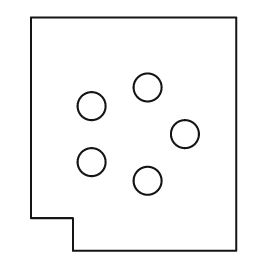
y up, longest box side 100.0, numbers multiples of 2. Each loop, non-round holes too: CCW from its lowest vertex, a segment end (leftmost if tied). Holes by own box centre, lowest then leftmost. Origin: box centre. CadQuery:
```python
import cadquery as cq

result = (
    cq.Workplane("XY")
    .moveTo(-26.0, -50.0)
    .lineTo(44.0, -50.0)
    .lineTo(44.0, 50.0)
    .lineTo(-44.0, 50.0)
    .lineTo(-44.0, -36.0)
    .lineTo(-26.0, -36.0)
    .close()
    .moveTo(6.0, -20.0)
    .circle(6.0)
    .moveTo(-18.0, -12.0)
    .circle(6.0)
    .moveTo(22.0, 0.0)
    .circle(6.0)
    .moveTo(-18.0, 12.0)
    .circle(6.0)
    .moveTo(6.0, 20.0)
    .circle(6.0)
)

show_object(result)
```